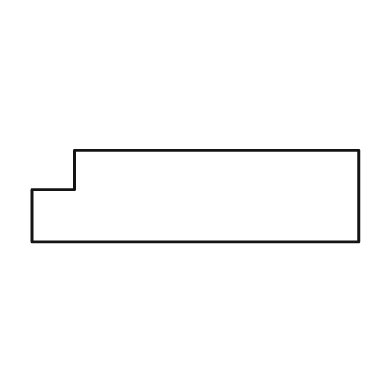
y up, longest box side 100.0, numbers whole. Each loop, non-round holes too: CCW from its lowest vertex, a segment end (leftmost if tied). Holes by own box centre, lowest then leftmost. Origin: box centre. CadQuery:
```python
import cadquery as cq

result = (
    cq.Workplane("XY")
    .moveTo(-50.0, -14.0)
    .lineTo(50.0, -14.0)
    .lineTo(50.0, 14.0)
    .lineTo(-37.0, 14.0)
    .lineTo(-37.0, 2.0)
    .lineTo(-50.0, 2.0)
    .close()
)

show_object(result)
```